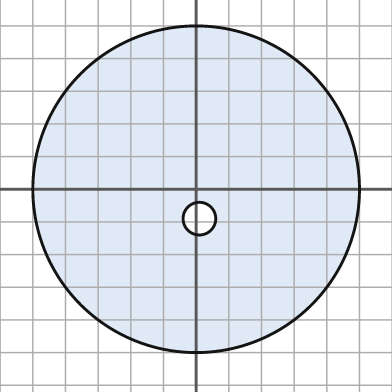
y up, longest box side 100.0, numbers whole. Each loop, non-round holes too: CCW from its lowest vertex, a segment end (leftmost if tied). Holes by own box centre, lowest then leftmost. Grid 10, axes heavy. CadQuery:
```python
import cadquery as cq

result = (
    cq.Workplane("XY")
    .moveTo(0.0, 0.0)
    .circle(50.0)
    .moveTo(1.0, -9.0)
    .circle(5.0)
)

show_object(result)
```